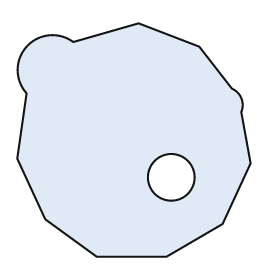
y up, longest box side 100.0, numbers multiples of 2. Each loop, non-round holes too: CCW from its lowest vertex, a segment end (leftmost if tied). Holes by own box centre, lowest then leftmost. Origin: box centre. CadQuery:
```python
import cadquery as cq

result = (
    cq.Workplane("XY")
    .moveTo(-16.0, -50.0)
    .lineTo(14.0, -50.0)
    .lineTo(38.0, -36.0)
    .lineTo(50.0, -10.0)
    .lineTo(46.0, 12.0)
    .threePointArc((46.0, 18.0), (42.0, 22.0))
    .lineTo(28.0, 40.0)
    .lineTo(2.0, 50.0)
    .lineTo(-26.0, 42.0)
    .threePointArc((-46.0, 40.0), (-46.0, 20.0))
    .lineTo(-50.0, -8.0)
    .lineTo(-38.0, -34.0)
    .close()
    .moveTo(16.0, -16.0)
    .circle(10.0)
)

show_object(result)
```